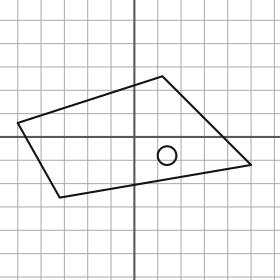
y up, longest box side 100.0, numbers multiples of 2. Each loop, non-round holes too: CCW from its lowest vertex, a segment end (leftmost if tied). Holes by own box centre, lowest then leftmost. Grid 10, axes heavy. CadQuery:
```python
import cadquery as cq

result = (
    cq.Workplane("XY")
    .moveTo(-32.0, -26.0)
    .lineTo(50.0, -12.0)
    .lineTo(12.0, 26.0)
    .lineTo(-50.0, 6.0)
    .close()
    .moveTo(14.0, -8.0)
    .circle(4.0)
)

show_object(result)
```